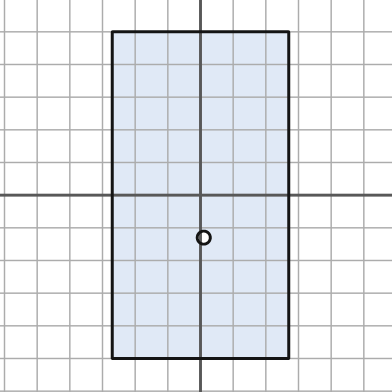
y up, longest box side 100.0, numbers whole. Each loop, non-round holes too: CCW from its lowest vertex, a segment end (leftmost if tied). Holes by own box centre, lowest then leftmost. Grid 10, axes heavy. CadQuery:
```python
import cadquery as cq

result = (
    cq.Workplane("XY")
    .moveTo(-27.0, -50.0)
    .lineTo(27.0, -50.0)
    .lineTo(27.0, 50.0)
    .lineTo(-27.0, 50.0)
    .close()
    .moveTo(1.0, -13.0)
    .circle(2.0)
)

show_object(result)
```